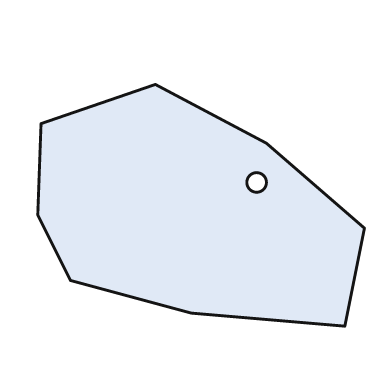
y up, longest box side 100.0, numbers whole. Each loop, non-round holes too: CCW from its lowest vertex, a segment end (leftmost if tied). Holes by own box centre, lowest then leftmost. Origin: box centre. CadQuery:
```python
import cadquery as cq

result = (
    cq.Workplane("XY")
    .moveTo(44.0, -37.0)
    .lineTo(50.0, -7.0)
    .lineTo(20.0, 19.0)
    .lineTo(-14.0, 37.0)
    .lineTo(-49.0, 25.0)
    .lineTo(-50.0, -3.0)
    .lineTo(-40.0, -23.0)
    .lineTo(-3.0, -33.0)
    .close()
    .moveTo(17.0, 7.0)
    .circle(3.0)
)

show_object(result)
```